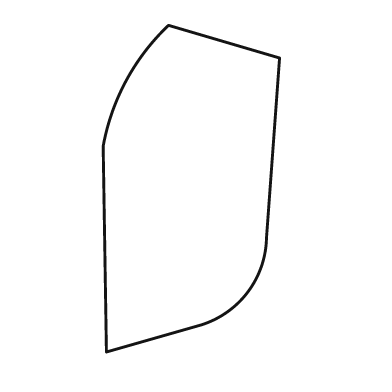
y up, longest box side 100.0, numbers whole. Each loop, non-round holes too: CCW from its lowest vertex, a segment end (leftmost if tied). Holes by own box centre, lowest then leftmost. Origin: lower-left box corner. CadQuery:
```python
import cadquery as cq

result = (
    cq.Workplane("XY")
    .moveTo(1.0, 0.0)
    .lineTo(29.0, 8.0)
    .threePointArc((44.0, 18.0), (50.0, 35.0))
    .lineTo(54.0, 90.0)
    .lineTo(20.0, 100.0)
    .threePointArc((7.0, 83.0), (0.0, 63.0))
    .close()
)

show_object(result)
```